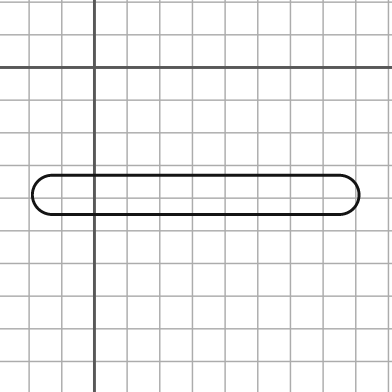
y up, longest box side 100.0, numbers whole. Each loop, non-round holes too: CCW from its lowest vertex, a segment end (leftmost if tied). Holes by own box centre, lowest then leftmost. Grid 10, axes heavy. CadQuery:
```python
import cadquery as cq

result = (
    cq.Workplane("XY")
    .moveTo(-13.0, -45.0)
    .lineTo(75.0, -45.0)
    .threePointArc((81.0, -39.0), (75.0, -33.0))
    .lineTo(-13.0, -33.0)
    .threePointArc((-19.0, -39.0), (-13.0, -45.0))
    .close()
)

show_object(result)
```